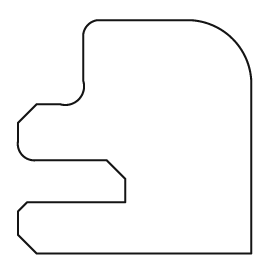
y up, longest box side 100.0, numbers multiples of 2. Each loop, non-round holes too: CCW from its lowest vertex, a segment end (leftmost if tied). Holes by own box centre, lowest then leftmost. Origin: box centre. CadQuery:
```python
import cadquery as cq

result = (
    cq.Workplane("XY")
    .moveTo(-42.0, -50.0)
    .lineTo(50.0, -50.0)
    .lineTo(50.0, 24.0)
    .threePointArc((42.0, 42.0), (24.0, 50.0))
    .lineTo(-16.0, 50.0)
    .threePointArc((-20.0, 48.0), (-22.0, 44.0))
    .lineTo(-22.0, 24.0)
    .threePointArc((-24.0, 16.0), (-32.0, 14.0))
    .lineTo(-42.0, 14.0)
    .lineTo(-50.0, 6.0)
    .lineTo(-50.0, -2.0)
    .threePointArc((-48.0, -8.0), (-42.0, -10.0))
    .lineTo(-12.0, -10.0)
    .lineTo(-4.0, -18.0)
    .lineTo(-4.0, -28.0)
    .lineTo(-46.0, -28.0)
    .lineTo(-50.0, -32.0)
    .lineTo(-50.0, -42.0)
    .close()
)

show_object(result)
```